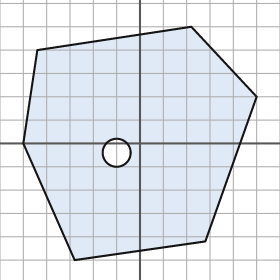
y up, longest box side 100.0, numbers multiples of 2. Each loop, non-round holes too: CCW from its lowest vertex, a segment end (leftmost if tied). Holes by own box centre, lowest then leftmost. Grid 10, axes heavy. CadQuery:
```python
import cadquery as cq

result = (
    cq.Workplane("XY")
    .moveTo(-28.0, -50.0)
    .lineTo(28.0, -42.0)
    .lineTo(50.0, 20.0)
    .lineTo(22.0, 50.0)
    .lineTo(-44.0, 40.0)
    .lineTo(-50.0, 0.0)
    .close()
    .moveTo(-10.0, -4.0)
    .circle(6.0)
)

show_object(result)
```